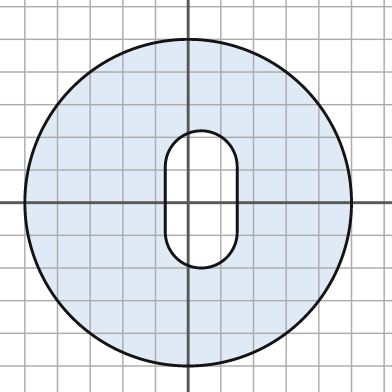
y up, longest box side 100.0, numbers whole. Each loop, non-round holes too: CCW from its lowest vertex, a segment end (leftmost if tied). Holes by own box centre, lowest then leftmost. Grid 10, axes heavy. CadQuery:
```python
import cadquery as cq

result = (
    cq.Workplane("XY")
    .moveTo(0.0, 0.0)
    .circle(50.0)
    .moveTo(-7.0, -9.0)
    .threePointArc((4.0, -20.0), (15.0, -9.0))
    .lineTo(15.0, 11.0)
    .threePointArc((4.0, 22.0), (-7.0, 11.0))
    .close()
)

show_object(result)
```